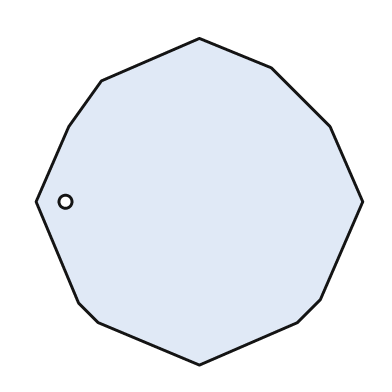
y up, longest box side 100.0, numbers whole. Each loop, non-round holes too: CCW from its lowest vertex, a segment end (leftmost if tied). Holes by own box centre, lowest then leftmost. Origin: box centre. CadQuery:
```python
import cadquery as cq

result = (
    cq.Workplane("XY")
    .moveTo(0.0, -50.0)
    .lineTo(30.0, -37.0)
    .lineTo(37.0, -30.0)
    .lineTo(50.0, 0.0)
    .lineTo(40.0, 23.0)
    .lineTo(22.0, 41.0)
    .lineTo(0.0, 50.0)
    .lineTo(-30.0, 37.0)
    .lineTo(-40.0, 23.0)
    .lineTo(-50.0, 0.0)
    .lineTo(-37.0, -31.0)
    .lineTo(-31.0, -37.0)
    .close()
    .moveTo(-41.0, 0.0)
    .circle(2.0)
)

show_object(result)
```